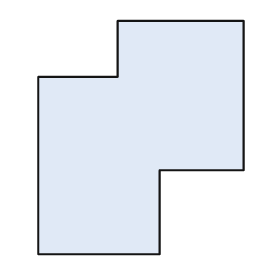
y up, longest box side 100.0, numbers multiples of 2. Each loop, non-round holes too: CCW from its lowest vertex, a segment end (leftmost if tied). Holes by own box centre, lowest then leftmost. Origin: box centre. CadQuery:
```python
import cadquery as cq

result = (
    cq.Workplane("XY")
    .moveTo(-44.0, -50.0)
    .lineTo(8.0, -50.0)
    .lineTo(8.0, -14.0)
    .lineTo(44.0, -14.0)
    .lineTo(44.0, 50.0)
    .lineTo(-10.0, 50.0)
    .lineTo(-10.0, 26.0)
    .lineTo(-44.0, 26.0)
    .close()
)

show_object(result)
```